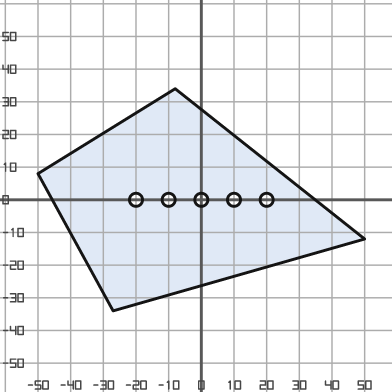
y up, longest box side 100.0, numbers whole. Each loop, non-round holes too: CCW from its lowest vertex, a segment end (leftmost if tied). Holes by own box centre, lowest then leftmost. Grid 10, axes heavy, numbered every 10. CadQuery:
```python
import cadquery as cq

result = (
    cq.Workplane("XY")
    .moveTo(-27.0, -34.0)
    .lineTo(50.0, -12.0)
    .lineTo(-8.0, 34.0)
    .lineTo(-50.0, 8.0)
    .close()
    .moveTo(-20.0, 0.0)
    .circle(2.0)
    .moveTo(-10.0, 0.0)
    .circle(2.0)
    .moveTo(0.0, 0.0)
    .circle(2.0)
    .moveTo(10.0, 0.0)
    .circle(2.0)
    .moveTo(20.0, 0.0)
    .circle(2.0)
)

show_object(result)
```